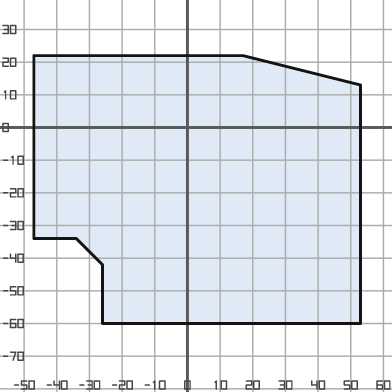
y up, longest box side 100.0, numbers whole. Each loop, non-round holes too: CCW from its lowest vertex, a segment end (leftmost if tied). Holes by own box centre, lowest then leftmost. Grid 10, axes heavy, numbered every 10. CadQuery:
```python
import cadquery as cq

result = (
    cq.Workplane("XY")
    .moveTo(-26.0, -60.0)
    .lineTo(53.0, -60.0)
    .lineTo(53.0, 13.0)
    .lineTo(17.0, 22.0)
    .lineTo(-47.0, 22.0)
    .lineTo(-47.0, -34.0)
    .lineTo(-34.0, -34.0)
    .lineTo(-26.0, -42.0)
    .close()
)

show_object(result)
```